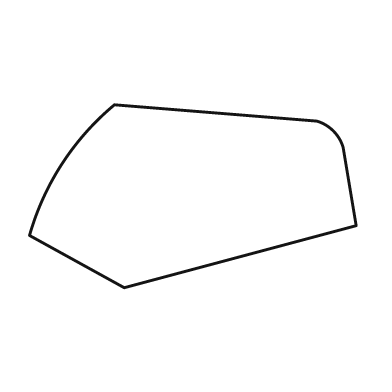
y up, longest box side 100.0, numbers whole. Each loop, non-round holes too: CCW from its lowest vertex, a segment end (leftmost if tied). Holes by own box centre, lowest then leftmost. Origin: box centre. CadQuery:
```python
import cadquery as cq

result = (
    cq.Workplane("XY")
    .moveTo(-21.0, -28.0)
    .lineTo(50.0, -9.0)
    .lineTo(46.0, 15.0)
    .threePointArc((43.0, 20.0), (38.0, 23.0))
    .lineTo(-24.0, 28.0)
    .threePointArc((-40.0, 10.0), (-50.0, -12.0))
    .close()
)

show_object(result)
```